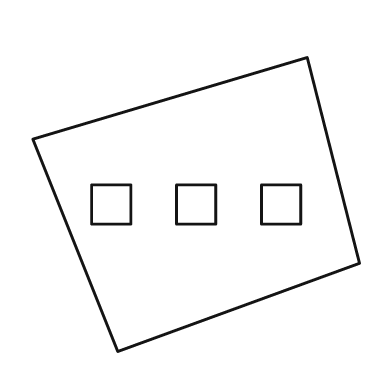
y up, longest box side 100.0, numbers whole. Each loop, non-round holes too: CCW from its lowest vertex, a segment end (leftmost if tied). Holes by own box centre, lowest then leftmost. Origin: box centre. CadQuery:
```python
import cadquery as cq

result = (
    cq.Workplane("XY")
    .moveTo(-24.0, -45.0)
    .lineTo(50.0, -18.0)
    .lineTo(34.0, 45.0)
    .lineTo(-50.0, 20.0)
    .close()
    .moveTo(-32.0, -6.0)
    .lineTo(-20.0, -6.0)
    .lineTo(-20.0, 6.0)
    .lineTo(-32.0, 6.0)
    .close()
    .moveTo(-6.0, -6.0)
    .lineTo(6.0, -6.0)
    .lineTo(6.0, 6.0)
    .lineTo(-6.0, 6.0)
    .close()
    .moveTo(20.0, -6.0)
    .lineTo(32.0, -6.0)
    .lineTo(32.0, 6.0)
    .lineTo(20.0, 6.0)
    .close()
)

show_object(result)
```